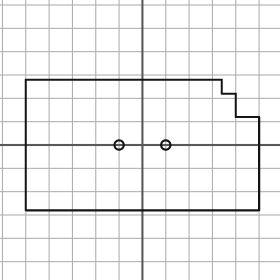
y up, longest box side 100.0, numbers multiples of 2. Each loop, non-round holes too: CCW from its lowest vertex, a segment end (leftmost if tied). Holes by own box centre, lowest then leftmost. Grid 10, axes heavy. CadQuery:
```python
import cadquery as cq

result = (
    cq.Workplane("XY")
    .moveTo(-50.0, -28.0)
    .lineTo(50.0, -28.0)
    .lineTo(50.0, 12.0)
    .lineTo(40.0, 12.0)
    .lineTo(40.0, 22.0)
    .lineTo(34.0, 22.0)
    .lineTo(34.0, 28.0)
    .lineTo(-50.0, 28.0)
    .close()
    .moveTo(-10.0, 0.0)
    .circle(2.0)
    .moveTo(10.0, 0.0)
    .circle(2.0)
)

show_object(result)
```